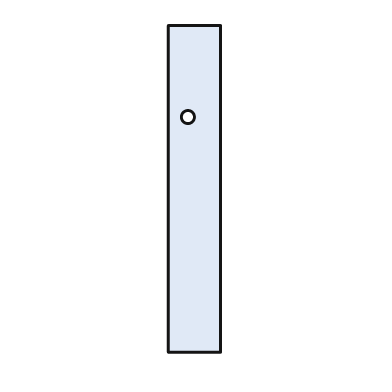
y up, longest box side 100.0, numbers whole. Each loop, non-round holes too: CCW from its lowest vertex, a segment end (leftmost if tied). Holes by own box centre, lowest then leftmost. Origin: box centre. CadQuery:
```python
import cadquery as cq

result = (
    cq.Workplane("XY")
    .moveTo(-8.0, -50.0)
    .lineTo(8.0, -50.0)
    .lineTo(8.0, 50.0)
    .lineTo(-8.0, 50.0)
    .close()
    .moveTo(-2.0, 22.0)
    .circle(2.0)
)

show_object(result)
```